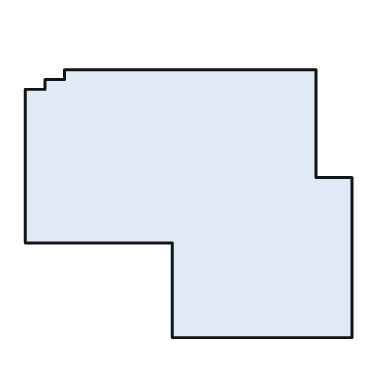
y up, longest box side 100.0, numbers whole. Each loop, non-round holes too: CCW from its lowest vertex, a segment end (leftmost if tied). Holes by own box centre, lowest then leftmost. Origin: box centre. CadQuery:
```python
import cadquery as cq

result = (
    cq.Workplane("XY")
    .moveTo(-5.0, -41.0)
    .lineTo(50.0, -41.0)
    .lineTo(50.0, 8.0)
    .lineTo(39.0, 8.0)
    .lineTo(39.0, 41.0)
    .lineTo(-38.0, 41.0)
    .lineTo(-38.0, 38.0)
    .lineTo(-44.0, 38.0)
    .lineTo(-44.0, 35.0)
    .lineTo(-50.0, 35.0)
    .lineTo(-50.0, -12.0)
    .lineTo(-5.0, -12.0)
    .close()
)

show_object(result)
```